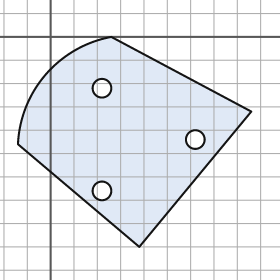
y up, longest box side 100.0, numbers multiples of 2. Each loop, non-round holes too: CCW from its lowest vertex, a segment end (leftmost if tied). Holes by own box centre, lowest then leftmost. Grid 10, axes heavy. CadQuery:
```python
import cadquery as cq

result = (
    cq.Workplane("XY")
    .moveTo(38.0, -90.0)
    .lineTo(86.0, -32.0)
    .lineTo(26.0, 0.0)
    .threePointArc((-2.0, -16.0), (-14.0, -46.0))
    .close()
    .moveTo(22.0, -66.0)
    .circle(4.0)
    .moveTo(62.0, -44.0)
    .circle(4.0)
    .moveTo(22.0, -22.0)
    .circle(4.0)
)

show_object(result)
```